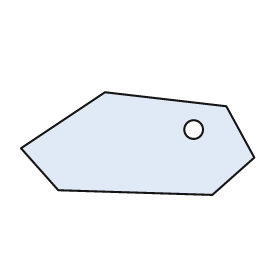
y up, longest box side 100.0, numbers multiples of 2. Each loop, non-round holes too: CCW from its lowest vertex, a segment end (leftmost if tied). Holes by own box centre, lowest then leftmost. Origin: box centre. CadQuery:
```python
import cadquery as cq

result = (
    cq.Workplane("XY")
    .moveTo(32.0, -22.0)
    .lineTo(50.0, -6.0)
    .lineTo(38.0, 16.0)
    .lineTo(-14.0, 22.0)
    .lineTo(-50.0, -2.0)
    .lineTo(-34.0, -20.0)
    .close()
    .moveTo(24.0, 6.0)
    .circle(4.0)
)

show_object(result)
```